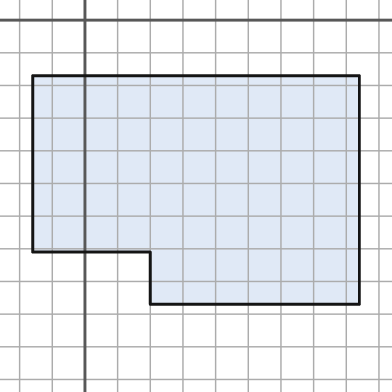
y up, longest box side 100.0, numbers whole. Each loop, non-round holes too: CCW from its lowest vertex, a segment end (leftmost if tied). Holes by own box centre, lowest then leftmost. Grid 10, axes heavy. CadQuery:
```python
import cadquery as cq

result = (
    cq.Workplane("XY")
    .moveTo(20.0, -87.0)
    .lineTo(84.0, -87.0)
    .lineTo(84.0, -17.0)
    .lineTo(-16.0, -17.0)
    .lineTo(-16.0, -71.0)
    .lineTo(20.0, -71.0)
    .close()
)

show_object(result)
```